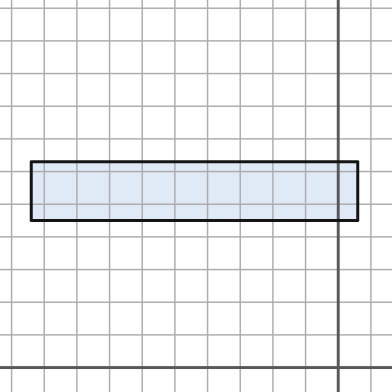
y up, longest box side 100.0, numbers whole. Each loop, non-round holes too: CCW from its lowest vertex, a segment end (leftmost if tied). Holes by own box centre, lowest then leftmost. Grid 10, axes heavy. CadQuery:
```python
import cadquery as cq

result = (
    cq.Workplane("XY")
    .moveTo(-94.0, 45.0)
    .lineTo(6.0, 45.0)
    .lineTo(6.0, 63.0)
    .lineTo(-94.0, 63.0)
    .close()
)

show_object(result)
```